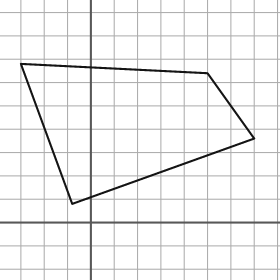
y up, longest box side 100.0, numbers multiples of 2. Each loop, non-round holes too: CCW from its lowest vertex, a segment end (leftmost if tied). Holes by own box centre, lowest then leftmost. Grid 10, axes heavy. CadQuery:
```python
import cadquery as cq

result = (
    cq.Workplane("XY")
    .moveTo(-8.0, 8.0)
    .lineTo(70.0, 36.0)
    .lineTo(50.0, 64.0)
    .lineTo(-30.0, 68.0)
    .close()
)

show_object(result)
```